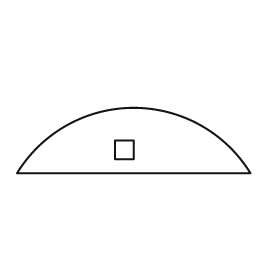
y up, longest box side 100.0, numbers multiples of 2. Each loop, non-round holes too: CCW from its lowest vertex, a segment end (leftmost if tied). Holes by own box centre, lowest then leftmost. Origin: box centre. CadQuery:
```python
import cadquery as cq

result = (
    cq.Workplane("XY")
    .moveTo(-50.0, -14.0)
    .lineTo(50.0, -14.0)
    .threePointArc((0.0, 14.0), (-50.0, -14.0))
    .close()
    .moveTo(-8.0, -8.0)
    .lineTo(0.0, -8.0)
    .lineTo(0.0, 0.0)
    .lineTo(-8.0, 0.0)
    .close()
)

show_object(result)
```